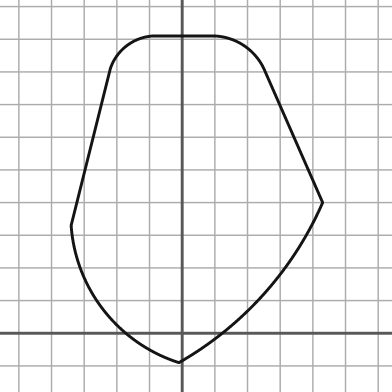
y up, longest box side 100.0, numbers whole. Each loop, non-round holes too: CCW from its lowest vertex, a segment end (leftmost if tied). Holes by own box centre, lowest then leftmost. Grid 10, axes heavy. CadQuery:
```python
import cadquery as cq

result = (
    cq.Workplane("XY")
    .moveTo(-1.0, -9.0)
    .threePointArc((25.0, 12.0), (43.0, 40.0))
    .lineTo(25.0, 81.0)
    .threePointArc((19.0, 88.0), (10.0, 91.0))
    .lineTo(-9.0, 91.0)
    .threePointArc((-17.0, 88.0), (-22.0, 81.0))
    .lineTo(-34.0, 33.0)
    .threePointArc((-24.0, 7.0), (-1.0, -9.0))
    .close()
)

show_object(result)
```